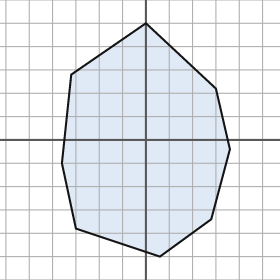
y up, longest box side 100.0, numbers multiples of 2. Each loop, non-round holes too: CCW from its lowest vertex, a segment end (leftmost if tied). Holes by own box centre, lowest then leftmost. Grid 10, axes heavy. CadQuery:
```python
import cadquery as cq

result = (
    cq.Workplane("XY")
    .moveTo(6.0, -50.0)
    .lineTo(28.0, -34.0)
    .lineTo(36.0, -4.0)
    .lineTo(30.0, 22.0)
    .lineTo(0.0, 50.0)
    .lineTo(-32.0, 28.0)
    .lineTo(-36.0, -10.0)
    .lineTo(-30.0, -38.0)
    .close()
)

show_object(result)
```